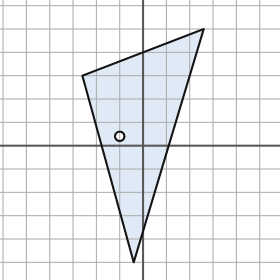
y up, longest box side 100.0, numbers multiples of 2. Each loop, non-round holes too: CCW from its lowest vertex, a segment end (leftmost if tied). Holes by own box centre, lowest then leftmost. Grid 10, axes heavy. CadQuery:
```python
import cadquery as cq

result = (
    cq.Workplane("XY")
    .moveTo(-4.0, -50.0)
    .lineTo(26.0, 50.0)
    .lineTo(-26.0, 30.0)
    .close()
    .moveTo(-10.0, 4.0)
    .circle(2.0)
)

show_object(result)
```